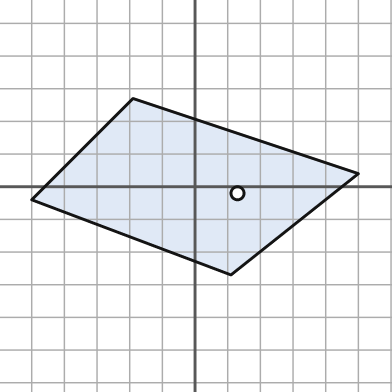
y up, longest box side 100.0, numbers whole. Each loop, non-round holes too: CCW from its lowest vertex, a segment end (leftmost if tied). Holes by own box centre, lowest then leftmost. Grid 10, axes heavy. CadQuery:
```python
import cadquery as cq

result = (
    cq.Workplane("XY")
    .moveTo(11.0, -27.0)
    .lineTo(50.0, 4.0)
    .lineTo(-19.0, 27.0)
    .lineTo(-50.0, -4.0)
    .close()
    .moveTo(13.0, -2.0)
    .circle(2.0)
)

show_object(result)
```